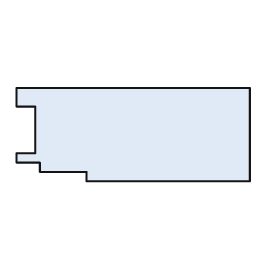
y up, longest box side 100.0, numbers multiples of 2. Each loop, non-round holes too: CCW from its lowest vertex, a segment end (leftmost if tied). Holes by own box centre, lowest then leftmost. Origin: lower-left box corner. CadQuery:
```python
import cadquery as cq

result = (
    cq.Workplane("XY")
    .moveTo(30.0, 0.0)
    .lineTo(100.0, 0.0)
    .lineTo(100.0, 40.0)
    .lineTo(0.0, 40.0)
    .lineTo(0.0, 32.0)
    .lineTo(8.0, 32.0)
    .lineTo(8.0, 12.0)
    .lineTo(0.0, 12.0)
    .lineTo(0.0, 8.0)
    .lineTo(10.0, 8.0)
    .lineTo(10.0, 4.0)
    .lineTo(30.0, 4.0)
    .close()
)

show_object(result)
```